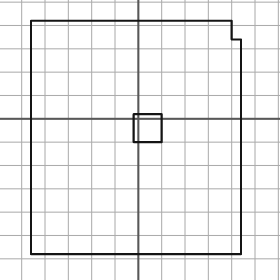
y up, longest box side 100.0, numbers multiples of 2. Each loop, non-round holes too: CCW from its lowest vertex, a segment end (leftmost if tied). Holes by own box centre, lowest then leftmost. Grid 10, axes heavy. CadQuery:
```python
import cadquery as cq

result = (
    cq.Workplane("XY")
    .moveTo(-46.0, -58.0)
    .lineTo(44.0, -58.0)
    .lineTo(44.0, 34.0)
    .lineTo(40.0, 34.0)
    .lineTo(40.0, 42.0)
    .lineTo(-46.0, 42.0)
    .close()
    .moveTo(-2.0, -10.0)
    .lineTo(10.0, -10.0)
    .lineTo(10.0, 2.0)
    .lineTo(-2.0, 2.0)
    .close()
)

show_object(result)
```